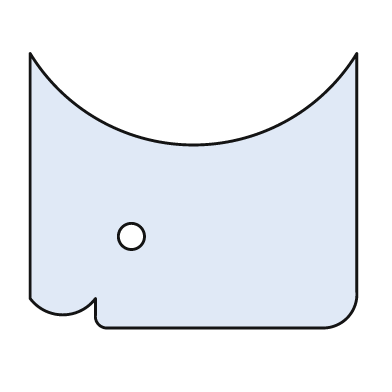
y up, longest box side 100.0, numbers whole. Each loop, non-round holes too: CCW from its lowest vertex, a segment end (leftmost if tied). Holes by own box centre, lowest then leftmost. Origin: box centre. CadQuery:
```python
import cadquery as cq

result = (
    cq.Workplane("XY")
    .moveTo(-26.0, -42.0)
    .lineTo(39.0, -42.0)
    .threePointArc((47.0, -39.0), (50.0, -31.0))
    .lineTo(50.0, 42.0)
    .threePointArc((0.0, 14.0), (-50.0, 42.0))
    .lineTo(-50.0, -33.0)
    .threePointArc((-40.0, -38.0), (-30.0, -33.0))
    .lineTo(-30.0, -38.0)
    .threePointArc((-29.0, -41.0), (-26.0, -42.0))
    .close()
    .moveTo(-19.0, -14.0)
    .circle(4.0)
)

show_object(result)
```